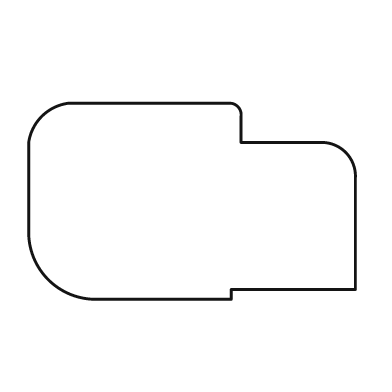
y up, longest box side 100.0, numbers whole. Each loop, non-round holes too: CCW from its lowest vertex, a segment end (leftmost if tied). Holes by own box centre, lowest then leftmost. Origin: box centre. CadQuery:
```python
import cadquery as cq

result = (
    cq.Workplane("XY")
    .moveTo(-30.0, -30.0)
    .lineTo(12.0, -30.0)
    .lineTo(12.0, -27.0)
    .lineTo(50.0, -27.0)
    .lineTo(50.0, 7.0)
    .threePointArc((47.0, 15.0), (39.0, 18.0))
    .lineTo(15.0, 18.0)
    .lineTo(15.0, 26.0)
    .threePointArc((14.0, 29.0), (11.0, 30.0))
    .lineTo(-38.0, 30.0)
    .threePointArc((-46.0, 26.0), (-50.0, 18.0))
    .lineTo(-50.0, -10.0)
    .threePointArc((-44.0, -24.0), (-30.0, -30.0))
    .close()
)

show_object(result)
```